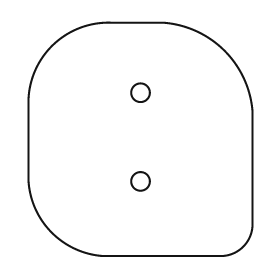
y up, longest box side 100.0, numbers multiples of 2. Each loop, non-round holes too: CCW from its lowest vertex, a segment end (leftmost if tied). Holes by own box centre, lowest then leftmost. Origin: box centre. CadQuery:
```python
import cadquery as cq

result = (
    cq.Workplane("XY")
    .moveTo(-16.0, -50.0)
    .lineTo(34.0, -50.0)
    .threePointArc((44.0, -46.0), (48.0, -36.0))
    .lineTo(48.0, 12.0)
    .threePointArc((36.0, 38.0), (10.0, 50.0))
    .lineTo(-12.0, 50.0)
    .threePointArc((-38.0, 40.0), (-48.0, 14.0))
    .lineTo(-48.0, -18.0)
    .threePointArc((-38.0, -40.0), (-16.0, -50.0))
    .close()
    .moveTo(0.0, -18.0)
    .circle(4.0)
    .moveTo(0.0, 20.0)
    .circle(4.0)
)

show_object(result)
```